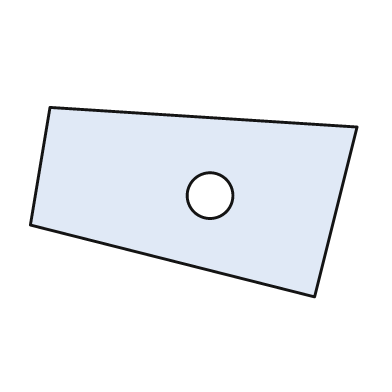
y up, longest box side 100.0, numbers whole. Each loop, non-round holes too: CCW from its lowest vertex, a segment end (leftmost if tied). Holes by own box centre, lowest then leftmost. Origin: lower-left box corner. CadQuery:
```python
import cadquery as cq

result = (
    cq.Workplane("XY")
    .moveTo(87.0, 0.0)
    .lineTo(100.0, 52.0)
    .lineTo(6.0, 58.0)
    .lineTo(0.0, 22.0)
    .close()
    .moveTo(55.0, 31.0)
    .circle(7.0)
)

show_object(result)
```